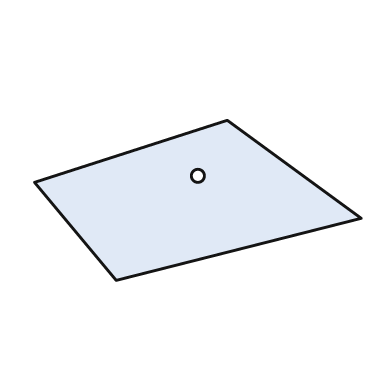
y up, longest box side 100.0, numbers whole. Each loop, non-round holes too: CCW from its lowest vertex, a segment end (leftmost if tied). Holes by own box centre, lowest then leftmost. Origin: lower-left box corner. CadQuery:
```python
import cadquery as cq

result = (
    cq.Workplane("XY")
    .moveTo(25.0, 0.0)
    .lineTo(100.0, 19.0)
    .lineTo(59.0, 49.0)
    .lineTo(0.0, 30.0)
    .close()
    .moveTo(50.0, 32.0)
    .circle(2.0)
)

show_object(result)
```